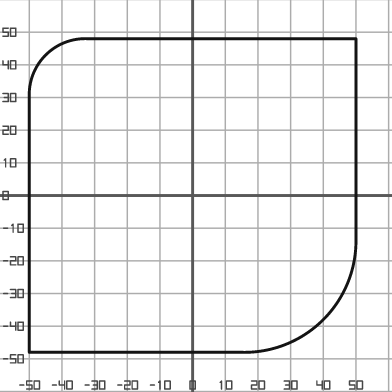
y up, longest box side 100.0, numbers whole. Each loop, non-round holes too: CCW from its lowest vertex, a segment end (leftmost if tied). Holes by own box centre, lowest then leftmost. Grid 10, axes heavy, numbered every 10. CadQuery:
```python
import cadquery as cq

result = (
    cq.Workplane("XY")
    .moveTo(-50.0, -48.0)
    .lineTo(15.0, -48.0)
    .threePointArc((40.0, -38.0), (50.0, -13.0))
    .lineTo(50.0, 48.0)
    .lineTo(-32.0, 48.0)
    .threePointArc((-45.0, 43.0), (-50.0, 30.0))
    .close()
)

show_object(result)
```